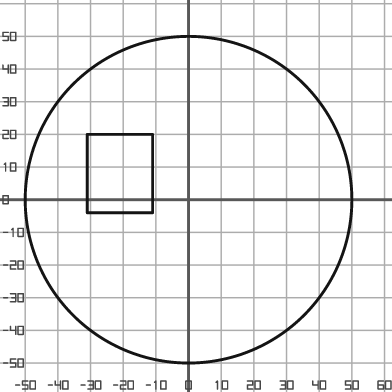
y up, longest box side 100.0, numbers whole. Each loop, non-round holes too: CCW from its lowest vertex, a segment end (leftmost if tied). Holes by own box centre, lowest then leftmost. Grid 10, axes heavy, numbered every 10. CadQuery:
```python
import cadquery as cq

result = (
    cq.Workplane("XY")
    .moveTo(0.0, 0.0)
    .circle(50.0)
    .moveTo(-31.0, -4.0)
    .lineTo(-11.0, -4.0)
    .lineTo(-11.0, 20.0)
    .lineTo(-31.0, 20.0)
    .close()
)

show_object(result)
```